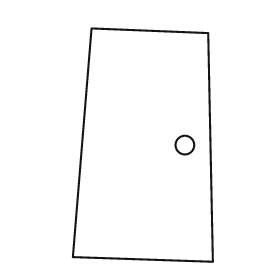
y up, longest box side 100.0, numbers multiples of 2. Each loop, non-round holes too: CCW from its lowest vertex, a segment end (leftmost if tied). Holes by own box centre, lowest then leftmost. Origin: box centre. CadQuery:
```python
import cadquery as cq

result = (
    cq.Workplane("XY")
    .moveTo(30.0, -50.0)
    .lineTo(28.0, 48.0)
    .lineTo(-22.0, 50.0)
    .lineTo(-30.0, -48.0)
    .close()
    .moveTo(18.0, 0.0)
    .circle(4.0)
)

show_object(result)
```